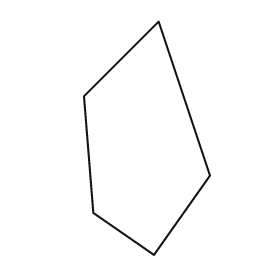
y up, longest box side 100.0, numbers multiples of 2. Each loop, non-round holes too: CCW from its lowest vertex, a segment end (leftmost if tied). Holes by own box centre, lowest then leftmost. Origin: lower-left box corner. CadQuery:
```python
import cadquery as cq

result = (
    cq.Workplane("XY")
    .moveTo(30.0, 0.0)
    .lineTo(54.0, 34.0)
    .lineTo(32.0, 100.0)
    .lineTo(0.0, 68.0)
    .lineTo(4.0, 18.0)
    .close()
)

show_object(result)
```